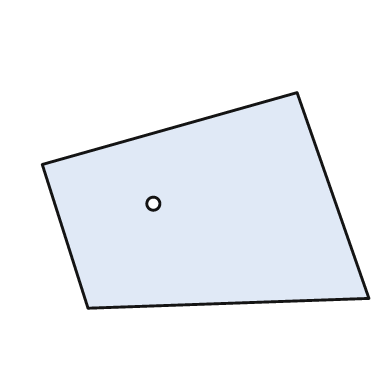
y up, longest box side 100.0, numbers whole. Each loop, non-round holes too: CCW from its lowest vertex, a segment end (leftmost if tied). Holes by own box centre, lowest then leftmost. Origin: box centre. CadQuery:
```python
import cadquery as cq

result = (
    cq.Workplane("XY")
    .moveTo(-36.0, -33.0)
    .lineTo(50.0, -30.0)
    .lineTo(28.0, 33.0)
    .lineTo(-50.0, 11.0)
    .close()
    .moveTo(-16.0, -1.0)
    .circle(2.0)
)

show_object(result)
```